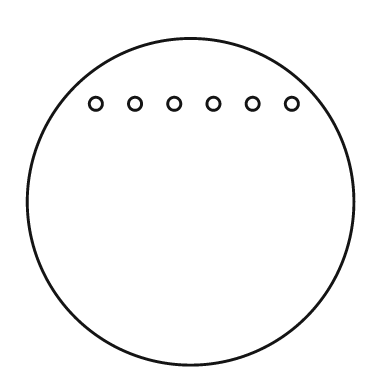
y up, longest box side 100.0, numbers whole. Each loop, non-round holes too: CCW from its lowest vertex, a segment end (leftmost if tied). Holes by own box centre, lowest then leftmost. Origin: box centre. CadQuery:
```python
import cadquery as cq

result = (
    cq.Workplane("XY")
    .moveTo(0.0, 0.0)
    .circle(50.0)
    .moveTo(-29.0, 30.0)
    .circle(2.0)
    .moveTo(-17.0, 30.0)
    .circle(2.0)
    .moveTo(-5.0, 30.0)
    .circle(2.0)
    .moveTo(7.0, 30.0)
    .circle(2.0)
    .moveTo(19.0, 30.0)
    .circle(2.0)
    .moveTo(31.0, 30.0)
    .circle(2.0)
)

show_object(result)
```